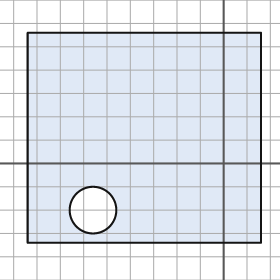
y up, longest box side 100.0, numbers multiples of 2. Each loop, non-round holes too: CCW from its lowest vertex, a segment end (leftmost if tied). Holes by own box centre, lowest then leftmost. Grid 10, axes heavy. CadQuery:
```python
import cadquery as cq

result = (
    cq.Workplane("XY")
    .moveTo(-84.0, -34.0)
    .lineTo(16.0, -34.0)
    .lineTo(16.0, 56.0)
    .lineTo(-84.0, 56.0)
    .close()
    .moveTo(-56.0, -20.0)
    .circle(10.0)
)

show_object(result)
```